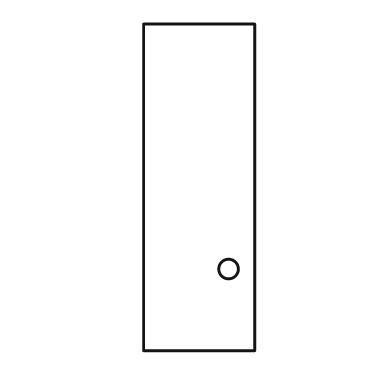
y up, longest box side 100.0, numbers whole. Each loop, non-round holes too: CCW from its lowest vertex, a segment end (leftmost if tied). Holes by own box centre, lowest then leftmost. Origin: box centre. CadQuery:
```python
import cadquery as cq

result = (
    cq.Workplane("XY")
    .moveTo(-17.0, -50.0)
    .lineTo(17.0, -50.0)
    .lineTo(17.0, 50.0)
    .lineTo(-17.0, 50.0)
    .close()
    .moveTo(9.0, -25.0)
    .circle(3.0)
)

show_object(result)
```